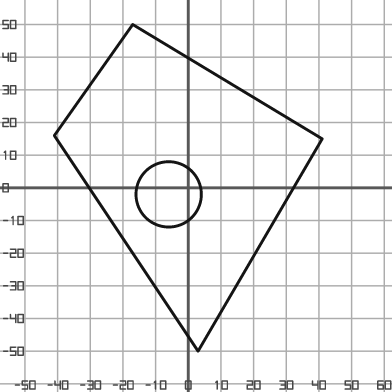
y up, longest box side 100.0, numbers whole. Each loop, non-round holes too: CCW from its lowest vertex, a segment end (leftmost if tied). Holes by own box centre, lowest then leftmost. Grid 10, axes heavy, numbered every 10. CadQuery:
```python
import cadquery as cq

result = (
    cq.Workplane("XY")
    .moveTo(3.0, -50.0)
    .lineTo(41.0, 15.0)
    .lineTo(-17.0, 50.0)
    .lineTo(-41.0, 16.0)
    .close()
    .moveTo(-6.0, -2.0)
    .circle(10.0)
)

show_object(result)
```